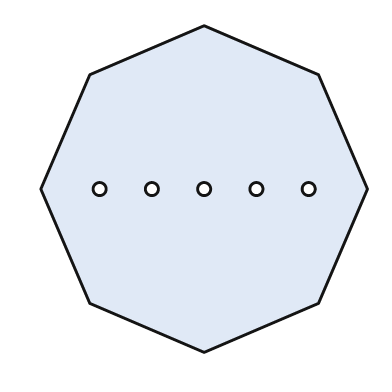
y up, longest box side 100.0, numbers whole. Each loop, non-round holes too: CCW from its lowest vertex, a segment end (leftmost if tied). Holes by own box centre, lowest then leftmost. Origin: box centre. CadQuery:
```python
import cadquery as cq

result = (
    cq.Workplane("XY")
    .moveTo(0.0, -50.0)
    .lineTo(35.0, -35.0)
    .lineTo(50.0, 0.0)
    .lineTo(35.0, 35.0)
    .lineTo(0.0, 50.0)
    .lineTo(-35.0, 35.0)
    .lineTo(-50.0, 0.0)
    .lineTo(-35.0, -35.0)
    .close()
    .moveTo(-32.0, 0.0)
    .circle(2.0)
    .moveTo(-16.0, 0.0)
    .circle(2.0)
    .moveTo(0.0, 0.0)
    .circle(2.0)
    .moveTo(16.0, 0.0)
    .circle(2.0)
    .moveTo(32.0, 0.0)
    .circle(2.0)
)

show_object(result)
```